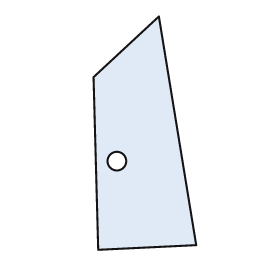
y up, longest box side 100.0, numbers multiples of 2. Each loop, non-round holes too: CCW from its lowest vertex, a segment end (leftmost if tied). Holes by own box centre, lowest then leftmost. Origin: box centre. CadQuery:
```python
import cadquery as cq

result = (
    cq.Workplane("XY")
    .moveTo(-20.0, -50.0)
    .lineTo(22.0, -48.0)
    .lineTo(6.0, 50.0)
    .lineTo(-22.0, 24.0)
    .close()
    .moveTo(-12.0, -12.0)
    .circle(4.0)
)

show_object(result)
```